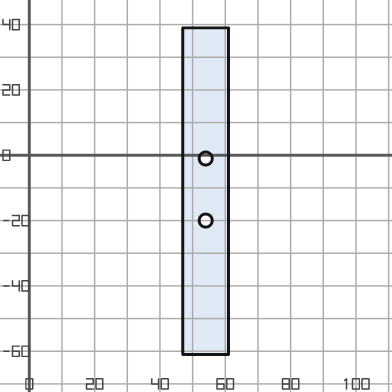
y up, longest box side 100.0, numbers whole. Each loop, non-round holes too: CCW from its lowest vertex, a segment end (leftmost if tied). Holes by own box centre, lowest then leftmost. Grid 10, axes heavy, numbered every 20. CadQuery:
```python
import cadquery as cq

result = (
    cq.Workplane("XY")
    .moveTo(47.0, -61.0)
    .lineTo(61.0, -61.0)
    .lineTo(61.0, 39.0)
    .lineTo(47.0, 39.0)
    .close()
    .moveTo(54.0, -20.0)
    .circle(2.0)
    .moveTo(54.0, -1.0)
    .circle(2.0)
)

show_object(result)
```